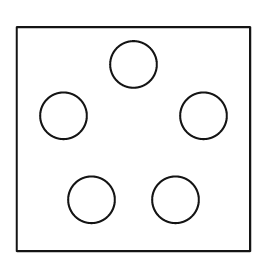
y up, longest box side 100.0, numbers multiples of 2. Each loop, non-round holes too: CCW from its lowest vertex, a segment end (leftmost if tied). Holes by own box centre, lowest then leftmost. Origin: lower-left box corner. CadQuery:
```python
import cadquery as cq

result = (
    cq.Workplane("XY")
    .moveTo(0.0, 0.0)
    .lineTo(100.0, 0.0)
    .lineTo(100.0, 96.0)
    .lineTo(0.0, 96.0)
    .close()
    .moveTo(32.0, 22.0)
    .circle(10.0)
    .moveTo(68.0, 22.0)
    .circle(10.0)
    .moveTo(20.0, 58.0)
    .circle(10.0)
    .moveTo(80.0, 58.0)
    .circle(10.0)
    .moveTo(50.0, 80.0)
    .circle(10.0)
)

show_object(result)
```